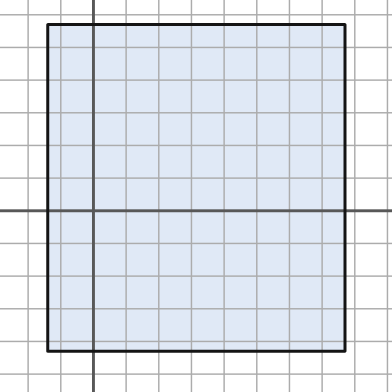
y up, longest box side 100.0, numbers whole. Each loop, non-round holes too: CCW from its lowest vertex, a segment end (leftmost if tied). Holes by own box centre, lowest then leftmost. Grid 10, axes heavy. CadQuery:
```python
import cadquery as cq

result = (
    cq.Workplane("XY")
    .moveTo(-14.0, -43.0)
    .lineTo(77.0, -43.0)
    .lineTo(77.0, 57.0)
    .lineTo(-14.0, 57.0)
    .close()
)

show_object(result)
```